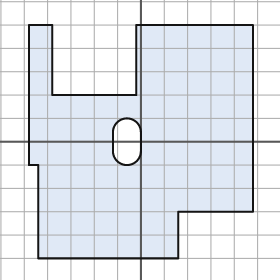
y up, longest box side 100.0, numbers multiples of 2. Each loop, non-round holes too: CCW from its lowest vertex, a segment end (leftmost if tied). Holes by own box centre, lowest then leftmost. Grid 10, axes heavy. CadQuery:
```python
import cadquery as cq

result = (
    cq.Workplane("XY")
    .moveTo(-44.0, -50.0)
    .lineTo(16.0, -50.0)
    .lineTo(16.0, -30.0)
    .lineTo(48.0, -30.0)
    .lineTo(48.0, 50.0)
    .lineTo(-2.0, 50.0)
    .lineTo(-2.0, 20.0)
    .lineTo(-38.0, 20.0)
    .lineTo(-38.0, 50.0)
    .lineTo(-48.0, 50.0)
    .lineTo(-48.0, -10.0)
    .lineTo(-44.0, -10.0)
    .close()
    .moveTo(-12.0, -4.0)
    .threePointArc((-6.0, -10.0), (0.0, -4.0))
    .lineTo(0.0, 4.0)
    .threePointArc((-6.0, 10.0), (-12.0, 4.0))
    .close()
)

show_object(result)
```